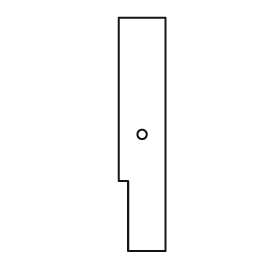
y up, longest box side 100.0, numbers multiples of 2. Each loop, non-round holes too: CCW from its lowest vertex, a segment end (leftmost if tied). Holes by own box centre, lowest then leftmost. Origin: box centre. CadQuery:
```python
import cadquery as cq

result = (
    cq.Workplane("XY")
    .moveTo(-6.0, -50.0)
    .lineTo(10.0, -50.0)
    .lineTo(10.0, 50.0)
    .lineTo(-10.0, 50.0)
    .lineTo(-10.0, -20.0)
    .lineTo(-6.0, -20.0)
    .close()
    .moveTo(0.0, 0.0)
    .circle(2.0)
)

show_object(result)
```